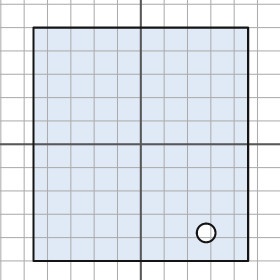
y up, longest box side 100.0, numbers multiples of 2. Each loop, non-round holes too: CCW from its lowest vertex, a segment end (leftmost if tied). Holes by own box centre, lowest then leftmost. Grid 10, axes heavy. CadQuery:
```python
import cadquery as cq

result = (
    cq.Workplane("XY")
    .moveTo(-46.0, -50.0)
    .lineTo(46.0, -50.0)
    .lineTo(46.0, 50.0)
    .lineTo(-46.0, 50.0)
    .close()
    .moveTo(28.0, -38.0)
    .circle(4.0)
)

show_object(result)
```